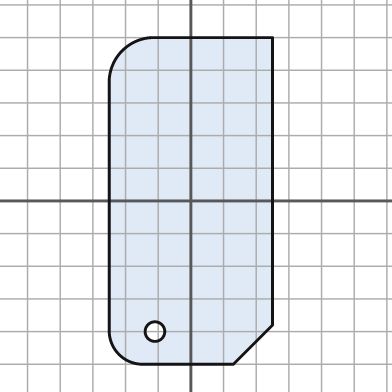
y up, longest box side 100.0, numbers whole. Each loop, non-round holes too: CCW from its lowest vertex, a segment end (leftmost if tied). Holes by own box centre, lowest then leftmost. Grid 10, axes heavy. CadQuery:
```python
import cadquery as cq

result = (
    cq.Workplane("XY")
    .moveTo(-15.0, -50.0)
    .lineTo(13.0, -50.0)
    .lineTo(25.0, -38.0)
    .lineTo(25.0, 50.0)
    .lineTo(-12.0, 50.0)
    .threePointArc((-21.0, 46.0), (-25.0, 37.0))
    .lineTo(-25.0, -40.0)
    .threePointArc((-22.0, -47.0), (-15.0, -50.0))
    .close()
    .moveTo(-11.0, -40.0)
    .circle(3.0)
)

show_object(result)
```